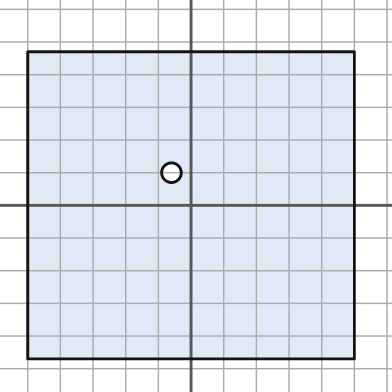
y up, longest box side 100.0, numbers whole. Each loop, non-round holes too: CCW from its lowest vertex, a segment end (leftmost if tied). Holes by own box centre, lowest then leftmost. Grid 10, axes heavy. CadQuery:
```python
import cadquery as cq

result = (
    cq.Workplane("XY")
    .moveTo(-50.0, -47.0)
    .lineTo(50.0, -47.0)
    .lineTo(50.0, 47.0)
    .lineTo(-50.0, 47.0)
    .close()
    .moveTo(-6.0, 10.0)
    .circle(3.0)
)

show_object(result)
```